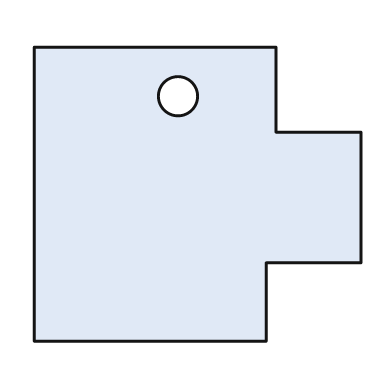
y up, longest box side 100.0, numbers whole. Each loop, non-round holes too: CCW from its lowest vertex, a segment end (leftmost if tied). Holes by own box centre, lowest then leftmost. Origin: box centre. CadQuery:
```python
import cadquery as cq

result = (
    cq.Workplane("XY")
    .moveTo(-50.0, -45.0)
    .lineTo(21.0, -45.0)
    .lineTo(21.0, -21.0)
    .lineTo(50.0, -21.0)
    .lineTo(50.0, 19.0)
    .lineTo(24.0, 19.0)
    .lineTo(24.0, 45.0)
    .lineTo(-50.0, 45.0)
    .close()
    .moveTo(-6.0, 30.0)
    .circle(6.0)
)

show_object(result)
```